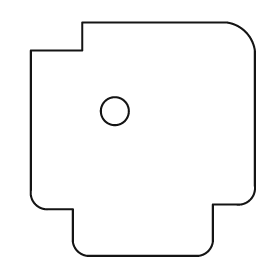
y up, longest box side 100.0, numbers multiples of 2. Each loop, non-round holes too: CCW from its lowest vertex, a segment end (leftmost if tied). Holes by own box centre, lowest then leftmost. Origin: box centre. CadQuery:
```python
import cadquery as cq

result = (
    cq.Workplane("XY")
    .moveTo(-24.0, -50.0)
    .lineTo(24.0, -50.0)
    .threePointArc((28.0, -48.0), (30.0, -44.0))
    .lineTo(30.0, -28.0)
    .lineTo(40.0, -28.0)
    .threePointArc((46.0, -26.0), (48.0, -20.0))
    .lineTo(48.0, 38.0)
    .threePointArc((44.0, 46.0), (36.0, 50.0))
    .lineTo(-26.0, 50.0)
    .lineTo(-26.0, 38.0)
    .lineTo(-48.0, 38.0)
    .lineTo(-48.0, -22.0)
    .threePointArc((-46.0, -28.0), (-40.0, -30.0))
    .lineTo(-30.0, -30.0)
    .lineTo(-30.0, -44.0)
    .threePointArc((-28.0, -48.0), (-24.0, -50.0))
    .close()
    .moveTo(-12.0, 12.0)
    .circle(6.0)
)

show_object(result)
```